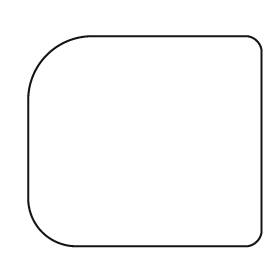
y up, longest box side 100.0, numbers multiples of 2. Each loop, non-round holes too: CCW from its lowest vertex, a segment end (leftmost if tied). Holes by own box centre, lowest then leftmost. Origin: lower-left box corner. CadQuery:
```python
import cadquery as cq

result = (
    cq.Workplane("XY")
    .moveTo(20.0, 0.0)
    .lineTo(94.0, 0.0)
    .threePointArc((98.0, 2.0), (100.0, 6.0))
    .lineTo(100.0, 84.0)
    .threePointArc((98.0, 88.0), (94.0, 90.0))
    .lineTo(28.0, 90.0)
    .threePointArc((8.0, 82.0), (0.0, 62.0))
    .lineTo(0.0, 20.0)
    .threePointArc((6.0, 6.0), (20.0, 0.0))
    .close()
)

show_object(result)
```